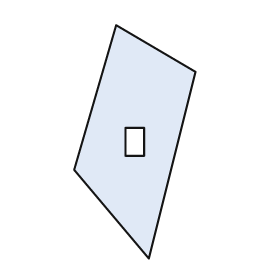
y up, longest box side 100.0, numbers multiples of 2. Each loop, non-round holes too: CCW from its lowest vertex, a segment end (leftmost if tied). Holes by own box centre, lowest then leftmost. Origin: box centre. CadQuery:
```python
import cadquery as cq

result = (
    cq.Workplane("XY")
    .moveTo(6.0, -50.0)
    .lineTo(26.0, 30.0)
    .lineTo(-8.0, 50.0)
    .lineTo(-26.0, -12.0)
    .close()
    .moveTo(-4.0, -6.0)
    .lineTo(4.0, -6.0)
    .lineTo(4.0, 6.0)
    .lineTo(-4.0, 6.0)
    .close()
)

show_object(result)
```